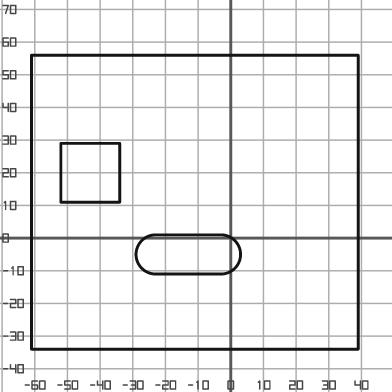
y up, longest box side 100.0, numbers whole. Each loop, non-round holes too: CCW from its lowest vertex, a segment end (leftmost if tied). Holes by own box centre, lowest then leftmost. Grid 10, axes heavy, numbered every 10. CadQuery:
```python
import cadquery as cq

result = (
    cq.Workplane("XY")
    .moveTo(-61.0, -34.0)
    .lineTo(39.0, -34.0)
    .lineTo(39.0, 56.0)
    .lineTo(-61.0, 56.0)
    .close()
    .moveTo(-23.0, -11.0)
    .lineTo(-3.0, -11.0)
    .threePointArc((3.0, -5.0), (-3.0, 1.0))
    .lineTo(-23.0, 1.0)
    .threePointArc((-29.0, -5.0), (-23.0, -11.0))
    .close()
    .moveTo(-52.0, 11.0)
    .lineTo(-34.0, 11.0)
    .lineTo(-34.0, 29.0)
    .lineTo(-52.0, 29.0)
    .close()
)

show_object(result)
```